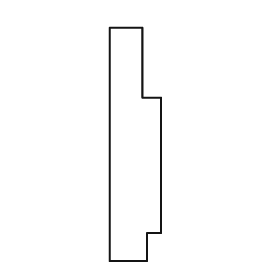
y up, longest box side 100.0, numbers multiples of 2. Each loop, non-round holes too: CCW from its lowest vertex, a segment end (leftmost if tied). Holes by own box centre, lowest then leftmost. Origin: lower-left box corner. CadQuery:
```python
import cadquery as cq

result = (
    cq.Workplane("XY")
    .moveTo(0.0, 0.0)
    .lineTo(16.0, 0.0)
    .lineTo(16.0, 12.0)
    .lineTo(22.0, 12.0)
    .lineTo(22.0, 70.0)
    .lineTo(14.0, 70.0)
    .lineTo(14.0, 100.0)
    .lineTo(0.0, 100.0)
    .close()
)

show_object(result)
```